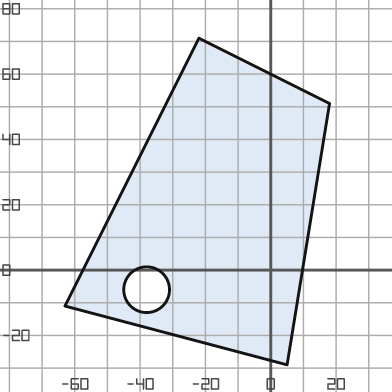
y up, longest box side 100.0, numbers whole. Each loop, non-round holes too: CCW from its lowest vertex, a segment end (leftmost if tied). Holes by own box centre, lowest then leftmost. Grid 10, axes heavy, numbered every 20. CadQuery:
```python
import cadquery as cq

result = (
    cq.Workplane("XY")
    .moveTo(5.0, -29.0)
    .lineTo(18.0, 51.0)
    .lineTo(-22.0, 71.0)
    .lineTo(-63.0, -11.0)
    .close()
    .moveTo(-38.0, -6.0)
    .circle(7.0)
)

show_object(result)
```